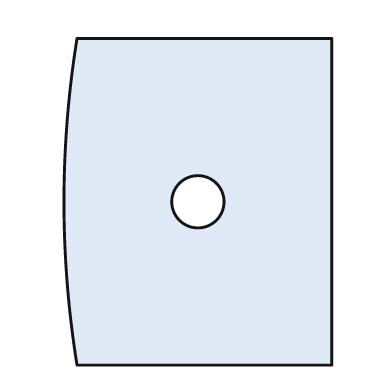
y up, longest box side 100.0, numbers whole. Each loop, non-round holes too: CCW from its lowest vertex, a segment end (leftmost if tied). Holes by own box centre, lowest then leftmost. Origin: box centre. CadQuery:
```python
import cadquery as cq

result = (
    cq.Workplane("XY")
    .moveTo(-37.0, -50.0)
    .lineTo(41.0, -50.0)
    .lineTo(41.0, 50.0)
    .lineTo(-37.0, 50.0)
    .threePointArc((-41.0, 0.0), (-37.0, -50.0))
    .close()
    .moveTo(0.0, 0.0)
    .circle(8.0)
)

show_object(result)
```